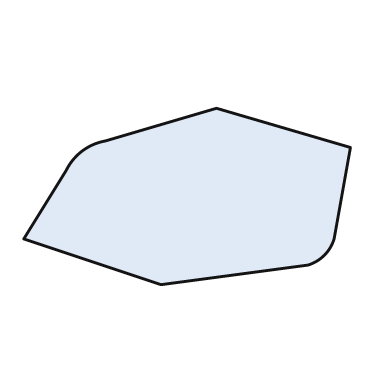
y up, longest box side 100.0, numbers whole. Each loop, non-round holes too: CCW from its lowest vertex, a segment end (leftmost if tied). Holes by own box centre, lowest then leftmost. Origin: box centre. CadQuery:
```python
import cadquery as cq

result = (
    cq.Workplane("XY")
    .moveTo(-8.0, -27.0)
    .lineTo(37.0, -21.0)
    .threePointArc((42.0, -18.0), (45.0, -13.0))
    .lineTo(50.0, 15.0)
    .lineTo(9.0, 27.0)
    .lineTo(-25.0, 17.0)
    .threePointArc((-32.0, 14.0), (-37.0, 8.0))
    .lineTo(-50.0, -13.0)
    .close()
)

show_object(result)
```